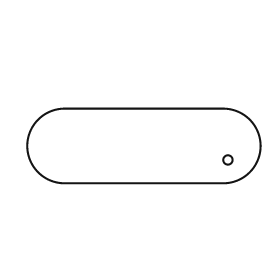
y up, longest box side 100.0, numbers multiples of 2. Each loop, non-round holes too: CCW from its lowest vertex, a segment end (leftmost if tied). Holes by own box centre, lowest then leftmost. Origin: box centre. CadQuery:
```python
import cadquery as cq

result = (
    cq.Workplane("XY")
    .moveTo(-34.0, -16.0)
    .lineTo(34.0, -16.0)
    .threePointArc((50.0, 0.0), (34.0, 16.0))
    .lineTo(-34.0, 16.0)
    .threePointArc((-50.0, 0.0), (-34.0, -16.0))
    .close()
    .moveTo(36.0, -6.0)
    .circle(2.0)
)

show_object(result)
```